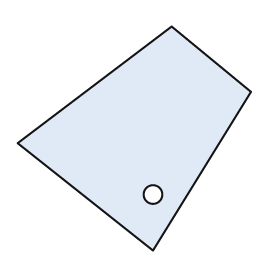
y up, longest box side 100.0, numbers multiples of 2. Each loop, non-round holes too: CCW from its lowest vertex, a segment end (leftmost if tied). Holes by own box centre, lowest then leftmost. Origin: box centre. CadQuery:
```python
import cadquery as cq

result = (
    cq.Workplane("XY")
    .moveTo(8.0, -48.0)
    .lineTo(50.0, 20.0)
    .lineTo(16.0, 48.0)
    .lineTo(-50.0, -2.0)
    .close()
    .moveTo(8.0, -24.0)
    .circle(4.0)
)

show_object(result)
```